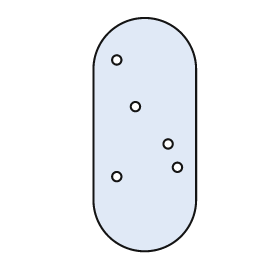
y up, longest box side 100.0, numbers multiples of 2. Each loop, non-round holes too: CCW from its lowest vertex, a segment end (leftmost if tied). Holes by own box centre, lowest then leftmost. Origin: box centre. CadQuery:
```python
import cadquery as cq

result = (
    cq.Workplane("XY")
    .moveTo(-22.0, -28.0)
    .threePointArc((0.0, -50.0), (22.0, -28.0))
    .lineTo(22.0, 28.0)
    .threePointArc((0.0, 50.0), (-22.0, 28.0))
    .close()
    .moveTo(-12.0, -18.0)
    .circle(2.0)
    .moveTo(14.0, -14.0)
    .circle(2.0)
    .moveTo(10.0, -4.0)
    .circle(2.0)
    .moveTo(-4.0, 12.0)
    .circle(2.0)
    .moveTo(-12.0, 32.0)
    .circle(2.0)
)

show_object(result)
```